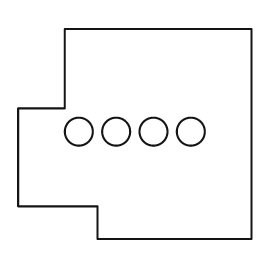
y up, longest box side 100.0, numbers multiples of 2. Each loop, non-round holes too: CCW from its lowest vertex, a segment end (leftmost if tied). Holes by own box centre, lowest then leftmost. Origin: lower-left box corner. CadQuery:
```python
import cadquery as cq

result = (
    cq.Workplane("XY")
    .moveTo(34.0, 0.0)
    .lineTo(100.0, 0.0)
    .lineTo(100.0, 90.0)
    .lineTo(20.0, 90.0)
    .lineTo(20.0, 56.0)
    .lineTo(0.0, 56.0)
    .lineTo(0.0, 14.0)
    .lineTo(34.0, 14.0)
    .close()
    .moveTo(26.0, 46.0)
    .circle(6.0)
    .moveTo(42.0, 46.0)
    .circle(6.0)
    .moveTo(58.0, 46.0)
    .circle(6.0)
    .moveTo(74.0, 46.0)
    .circle(6.0)
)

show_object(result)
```